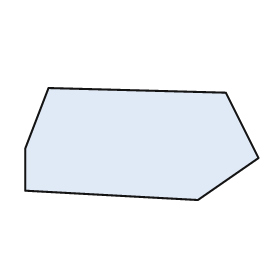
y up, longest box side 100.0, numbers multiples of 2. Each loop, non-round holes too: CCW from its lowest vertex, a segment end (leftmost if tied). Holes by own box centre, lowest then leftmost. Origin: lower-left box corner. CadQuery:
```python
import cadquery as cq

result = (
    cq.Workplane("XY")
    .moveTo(74.0, 0.0)
    .lineTo(100.0, 18.0)
    .lineTo(86.0, 46.0)
    .lineTo(10.0, 48.0)
    .lineTo(0.0, 22.0)
    .lineTo(0.0, 4.0)
    .close()
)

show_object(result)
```